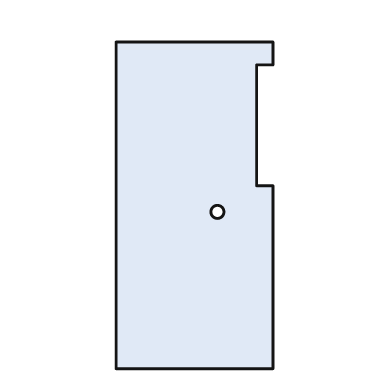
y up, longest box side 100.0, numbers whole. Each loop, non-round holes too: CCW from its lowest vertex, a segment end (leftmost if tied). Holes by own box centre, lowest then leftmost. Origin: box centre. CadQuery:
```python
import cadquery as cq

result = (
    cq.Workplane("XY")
    .moveTo(-24.0, -50.0)
    .lineTo(24.0, -50.0)
    .lineTo(24.0, 6.0)
    .lineTo(19.0, 6.0)
    .lineTo(19.0, 43.0)
    .lineTo(24.0, 43.0)
    .lineTo(24.0, 50.0)
    .lineTo(-24.0, 50.0)
    .close()
    .moveTo(7.0, -2.0)
    .circle(2.0)
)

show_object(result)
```